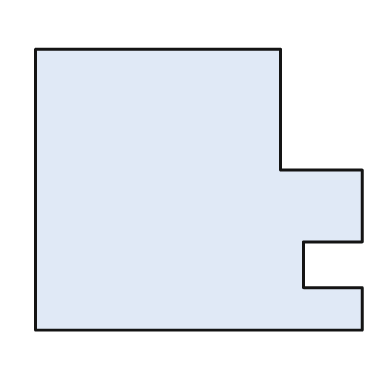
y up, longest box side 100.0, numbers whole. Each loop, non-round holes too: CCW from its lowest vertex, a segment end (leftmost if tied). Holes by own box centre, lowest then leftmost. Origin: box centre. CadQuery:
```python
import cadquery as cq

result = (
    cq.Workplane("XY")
    .moveTo(-50.0, -43.0)
    .lineTo(50.0, -43.0)
    .lineTo(50.0, -30.0)
    .lineTo(32.0, -30.0)
    .lineTo(32.0, -16.0)
    .lineTo(50.0, -16.0)
    .lineTo(50.0, 6.0)
    .lineTo(25.0, 6.0)
    .lineTo(25.0, 43.0)
    .lineTo(-50.0, 43.0)
    .close()
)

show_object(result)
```